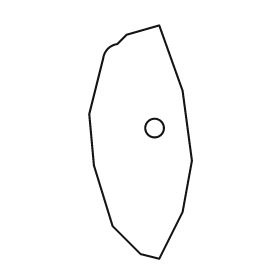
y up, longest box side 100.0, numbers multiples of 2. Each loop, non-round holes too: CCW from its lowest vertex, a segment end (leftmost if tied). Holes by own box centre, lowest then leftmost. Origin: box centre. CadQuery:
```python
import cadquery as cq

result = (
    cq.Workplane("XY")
    .moveTo(8.0, -50.0)
    .lineTo(18.0, -30.0)
    .lineTo(22.0, -8.0)
    .lineTo(18.0, 22.0)
    .lineTo(8.0, 50.0)
    .lineTo(-6.0, 46.0)
    .lineTo(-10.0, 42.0)
    .threePointArc((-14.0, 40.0), (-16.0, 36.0))
    .lineTo(-22.0, 12.0)
    .lineTo(-20.0, -10.0)
    .lineTo(-12.0, -36.0)
    .lineTo(0.0, -48.0)
    .close()
    .moveTo(6.0, 6.0)
    .circle(4.0)
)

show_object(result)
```